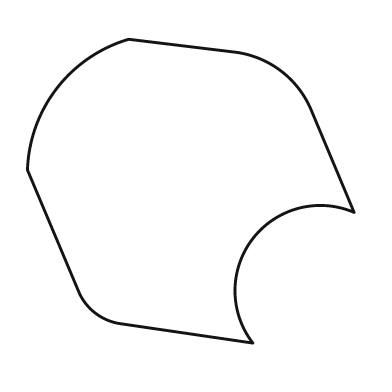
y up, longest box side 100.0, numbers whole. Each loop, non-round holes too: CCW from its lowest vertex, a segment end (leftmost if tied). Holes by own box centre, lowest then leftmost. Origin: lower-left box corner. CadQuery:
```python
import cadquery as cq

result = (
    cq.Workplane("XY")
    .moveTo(69.0, 0.0)
    .threePointArc((69.0, 32.0), (100.0, 40.0))
    .lineTo(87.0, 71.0)
    .threePointArc((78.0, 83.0), (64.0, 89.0))
    .lineTo(31.0, 93.0)
    .threePointArc((9.0, 78.0), (0.0, 53.0))
    .lineTo(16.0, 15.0)
    .threePointArc((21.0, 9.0), (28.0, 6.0))
    .close()
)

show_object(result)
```